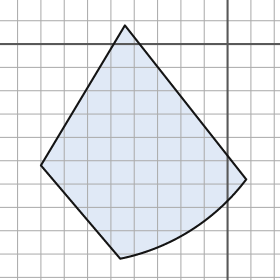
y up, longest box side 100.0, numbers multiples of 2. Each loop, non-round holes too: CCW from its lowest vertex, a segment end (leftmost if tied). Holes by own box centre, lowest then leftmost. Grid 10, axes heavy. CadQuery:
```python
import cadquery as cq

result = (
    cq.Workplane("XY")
    .moveTo(-46.0, -92.0)
    .threePointArc((-16.0, -80.0), (8.0, -58.0))
    .lineTo(-44.0, 8.0)
    .lineTo(-80.0, -52.0)
    .close()
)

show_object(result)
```